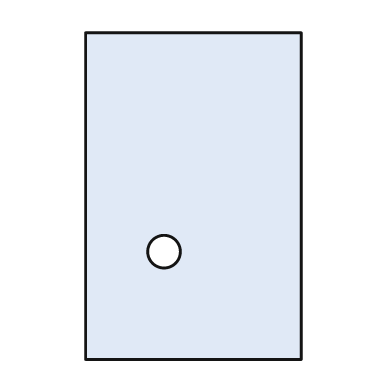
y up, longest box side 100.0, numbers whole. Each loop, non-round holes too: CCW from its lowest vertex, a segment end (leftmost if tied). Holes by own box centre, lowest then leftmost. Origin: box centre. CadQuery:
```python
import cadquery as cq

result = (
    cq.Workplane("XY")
    .moveTo(-33.0, -50.0)
    .lineTo(33.0, -50.0)
    .lineTo(33.0, 50.0)
    .lineTo(-33.0, 50.0)
    .close()
    .moveTo(-9.0, -17.0)
    .circle(5.0)
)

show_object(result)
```